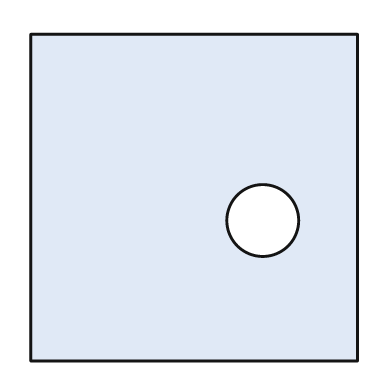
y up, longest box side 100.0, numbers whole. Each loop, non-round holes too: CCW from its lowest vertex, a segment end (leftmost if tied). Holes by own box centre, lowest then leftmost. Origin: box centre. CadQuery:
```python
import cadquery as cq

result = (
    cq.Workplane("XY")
    .moveTo(-50.0, -50.0)
    .lineTo(50.0, -50.0)
    .lineTo(50.0, 50.0)
    .lineTo(-50.0, 50.0)
    .close()
    .moveTo(21.0, -7.0)
    .circle(11.0)
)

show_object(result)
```